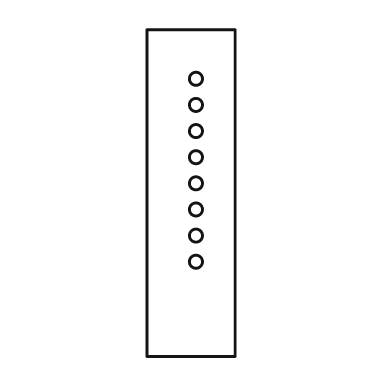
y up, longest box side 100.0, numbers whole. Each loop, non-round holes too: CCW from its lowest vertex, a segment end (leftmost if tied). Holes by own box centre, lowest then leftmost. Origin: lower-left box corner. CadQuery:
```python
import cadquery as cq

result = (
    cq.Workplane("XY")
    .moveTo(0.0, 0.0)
    .lineTo(27.0, 0.0)
    .lineTo(27.0, 100.0)
    .lineTo(0.0, 100.0)
    .close()
    .moveTo(15.0, 29.0)
    .circle(2.0)
    .moveTo(15.0, 37.0)
    .circle(2.0)
    .moveTo(15.0, 45.0)
    .circle(2.0)
    .moveTo(15.0, 53.0)
    .circle(2.0)
    .moveTo(15.0, 61.0)
    .circle(2.0)
    .moveTo(15.0, 69.0)
    .circle(2.0)
    .moveTo(15.0, 77.0)
    .circle(2.0)
    .moveTo(15.0, 85.0)
    .circle(2.0)
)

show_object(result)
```